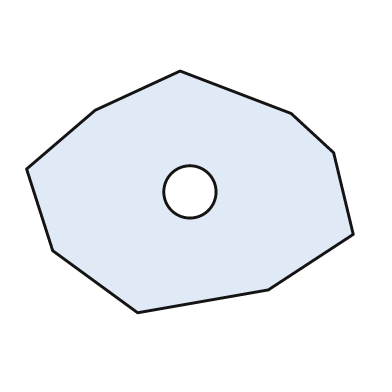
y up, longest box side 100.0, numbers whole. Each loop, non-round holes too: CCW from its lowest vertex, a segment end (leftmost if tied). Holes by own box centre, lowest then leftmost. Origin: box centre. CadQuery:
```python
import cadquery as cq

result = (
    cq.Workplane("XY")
    .moveTo(-16.0, -37.0)
    .lineTo(24.0, -30.0)
    .lineTo(50.0, -13.0)
    .lineTo(44.0, 12.0)
    .lineTo(31.0, 24.0)
    .lineTo(-3.0, 37.0)
    .lineTo(-29.0, 25.0)
    .lineTo(-50.0, 7.0)
    .lineTo(-42.0, -18.0)
    .close()
    .moveTo(0.0, 0.0)
    .circle(8.0)
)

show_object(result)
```